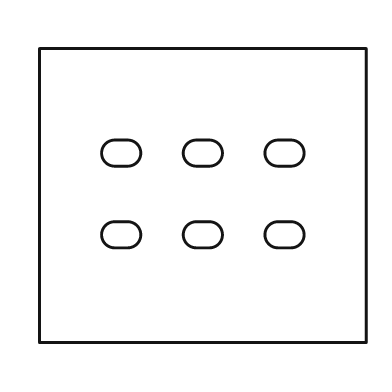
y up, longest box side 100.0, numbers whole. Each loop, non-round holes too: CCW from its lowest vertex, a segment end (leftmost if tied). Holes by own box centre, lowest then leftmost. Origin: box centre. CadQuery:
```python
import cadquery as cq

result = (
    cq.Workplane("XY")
    .moveTo(-50.0, -45.0)
    .lineTo(50.0, -45.0)
    .lineTo(50.0, 45.0)
    .lineTo(-50.0, 45.0)
    .close()
    .moveTo(-27.0, -16.0)
    .lineTo(-23.0, -16.0)
    .threePointArc((-19.0, -12.0), (-23.0, -8.0))
    .lineTo(-27.0, -8.0)
    .threePointArc((-31.0, -12.0), (-27.0, -16.0))
    .close()
    .moveTo(-2.0, -16.0)
    .lineTo(2.0, -16.0)
    .threePointArc((6.0, -12.0), (2.0, -8.0))
    .lineTo(-2.0, -8.0)
    .threePointArc((-6.0, -12.0), (-2.0, -16.0))
    .close()
    .moveTo(23.0, -16.0)
    .lineTo(27.0, -16.0)
    .threePointArc((31.0, -12.0), (27.0, -8.0))
    .lineTo(23.0, -8.0)
    .threePointArc((19.0, -12.0), (23.0, -16.0))
    .close()
    .moveTo(-27.0, 9.0)
    .lineTo(-23.0, 9.0)
    .threePointArc((-19.0, 13.0), (-23.0, 17.0))
    .lineTo(-27.0, 17.0)
    .threePointArc((-31.0, 13.0), (-27.0, 9.0))
    .close()
    .moveTo(-2.0, 9.0)
    .lineTo(2.0, 9.0)
    .threePointArc((6.0, 13.0), (2.0, 17.0))
    .lineTo(-2.0, 17.0)
    .threePointArc((-6.0, 13.0), (-2.0, 9.0))
    .close()
    .moveTo(23.0, 9.0)
    .lineTo(27.0, 9.0)
    .threePointArc((31.0, 13.0), (27.0, 17.0))
    .lineTo(23.0, 17.0)
    .threePointArc((19.0, 13.0), (23.0, 9.0))
    .close()
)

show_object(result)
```